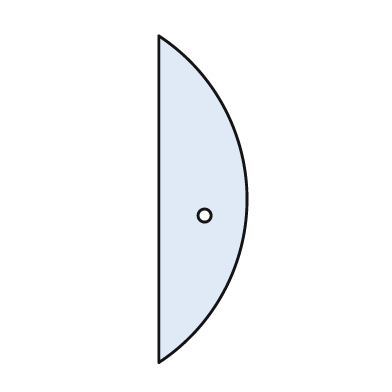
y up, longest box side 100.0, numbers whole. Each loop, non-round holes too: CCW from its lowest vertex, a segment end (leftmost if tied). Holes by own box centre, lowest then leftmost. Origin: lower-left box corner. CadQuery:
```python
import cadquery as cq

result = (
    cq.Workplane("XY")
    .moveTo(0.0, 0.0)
    .threePointArc((27.0, 50.0), (0.0, 100.0))
    .close()
    .moveTo(14.0, 45.0)
    .circle(2.0)
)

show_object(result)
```